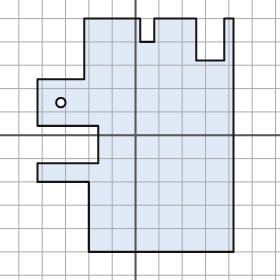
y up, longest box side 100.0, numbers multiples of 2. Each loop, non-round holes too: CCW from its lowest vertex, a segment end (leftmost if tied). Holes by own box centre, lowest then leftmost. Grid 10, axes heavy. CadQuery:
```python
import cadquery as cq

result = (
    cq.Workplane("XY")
    .moveTo(-20.0, -50.0)
    .lineTo(42.0, -50.0)
    .lineTo(42.0, 50.0)
    .lineTo(38.0, 50.0)
    .lineTo(38.0, 32.0)
    .lineTo(26.0, 32.0)
    .lineTo(26.0, 50.0)
    .lineTo(8.0, 50.0)
    .lineTo(8.0, 40.0)
    .lineTo(2.0, 40.0)
    .lineTo(2.0, 50.0)
    .lineTo(-22.0, 50.0)
    .lineTo(-22.0, 24.0)
    .lineTo(-42.0, 24.0)
    .lineTo(-42.0, 4.0)
    .lineTo(-16.0, 4.0)
    .lineTo(-16.0, -12.0)
    .lineTo(-42.0, -12.0)
    .lineTo(-42.0, -20.0)
    .lineTo(-20.0, -20.0)
    .close()
    .moveTo(-32.0, 14.0)
    .circle(2.0)
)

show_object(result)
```